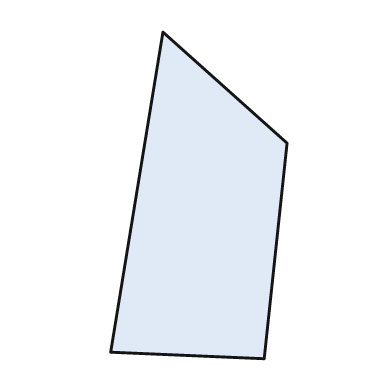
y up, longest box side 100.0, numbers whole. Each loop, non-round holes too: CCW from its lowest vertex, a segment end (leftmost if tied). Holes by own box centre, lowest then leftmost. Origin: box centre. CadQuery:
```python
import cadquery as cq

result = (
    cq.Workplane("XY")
    .moveTo(20.0, -50.0)
    .lineTo(27.0, 16.0)
    .lineTo(-11.0, 50.0)
    .lineTo(-27.0, -48.0)
    .close()
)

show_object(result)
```